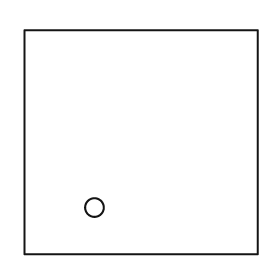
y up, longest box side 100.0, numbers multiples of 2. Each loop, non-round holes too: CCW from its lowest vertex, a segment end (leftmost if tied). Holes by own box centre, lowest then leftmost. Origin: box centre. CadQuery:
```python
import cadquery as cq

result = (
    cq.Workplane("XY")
    .moveTo(-50.0, -48.0)
    .lineTo(50.0, -48.0)
    .lineTo(50.0, 48.0)
    .lineTo(-50.0, 48.0)
    .close()
    .moveTo(-20.0, -28.0)
    .circle(4.0)
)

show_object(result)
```